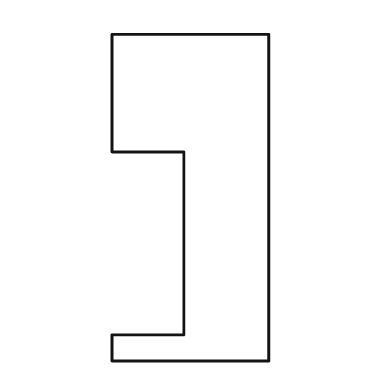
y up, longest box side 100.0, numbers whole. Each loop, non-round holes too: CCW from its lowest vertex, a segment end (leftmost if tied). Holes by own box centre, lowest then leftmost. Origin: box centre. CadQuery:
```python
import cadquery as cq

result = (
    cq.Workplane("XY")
    .moveTo(-24.0, -50.0)
    .lineTo(24.0, -50.0)
    .lineTo(24.0, 50.0)
    .lineTo(-24.0, 50.0)
    .lineTo(-24.0, 14.0)
    .lineTo(-2.0, 14.0)
    .lineTo(-2.0, -42.0)
    .lineTo(-24.0, -42.0)
    .close()
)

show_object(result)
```